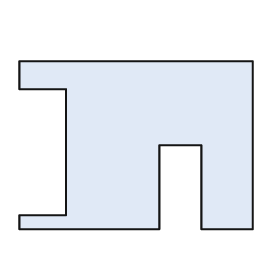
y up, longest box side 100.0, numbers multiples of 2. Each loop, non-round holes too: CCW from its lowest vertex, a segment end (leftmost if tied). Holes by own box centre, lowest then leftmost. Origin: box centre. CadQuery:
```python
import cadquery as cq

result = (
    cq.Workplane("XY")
    .moveTo(-50.0, -36.0)
    .lineTo(10.0, -36.0)
    .lineTo(10.0, 0.0)
    .lineTo(28.0, 0.0)
    .lineTo(28.0, -36.0)
    .lineTo(50.0, -36.0)
    .lineTo(50.0, 36.0)
    .lineTo(-50.0, 36.0)
    .lineTo(-50.0, 24.0)
    .lineTo(-30.0, 24.0)
    .lineTo(-30.0, -30.0)
    .lineTo(-50.0, -30.0)
    .close()
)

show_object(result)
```